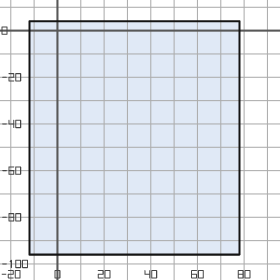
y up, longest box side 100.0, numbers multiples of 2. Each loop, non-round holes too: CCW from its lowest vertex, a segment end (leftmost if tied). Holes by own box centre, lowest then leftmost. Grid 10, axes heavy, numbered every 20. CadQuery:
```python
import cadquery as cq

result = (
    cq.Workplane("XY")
    .moveTo(-12.0, -96.0)
    .lineTo(78.0, -96.0)
    .lineTo(78.0, 4.0)
    .lineTo(-12.0, 4.0)
    .close()
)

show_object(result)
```